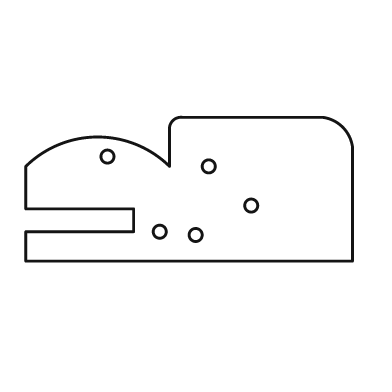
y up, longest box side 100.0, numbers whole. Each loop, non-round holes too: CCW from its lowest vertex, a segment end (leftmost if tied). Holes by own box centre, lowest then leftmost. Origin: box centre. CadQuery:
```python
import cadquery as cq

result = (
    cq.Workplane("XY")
    .moveTo(-50.0, -22.0)
    .lineTo(50.0, -22.0)
    .lineTo(50.0, 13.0)
    .threePointArc((47.0, 19.0), (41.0, 22.0))
    .lineTo(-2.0, 22.0)
    .threePointArc((-5.0, 21.0), (-6.0, 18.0))
    .lineTo(-6.0, 7.0)
    .threePointArc((-28.0, 16.0), (-50.0, 7.0))
    .lineTo(-50.0, -6.0)
    .lineTo(-17.0, -6.0)
    .lineTo(-17.0, -13.0)
    .lineTo(-50.0, -13.0)
    .close()
    .moveTo(2.0, -14.0)
    .circle(2.0)
    .moveTo(-9.0, -13.0)
    .circle(2.0)
    .moveTo(19.0, -5.0)
    .circle(2.0)
    .moveTo(6.0, 7.0)
    .circle(2.0)
    .moveTo(-25.0, 10.0)
    .circle(2.0)
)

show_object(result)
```